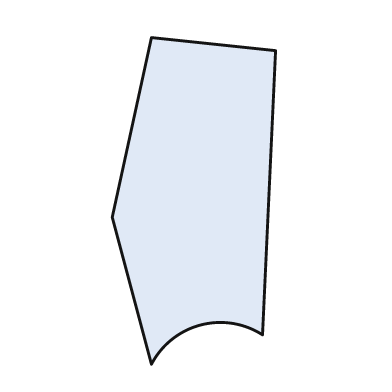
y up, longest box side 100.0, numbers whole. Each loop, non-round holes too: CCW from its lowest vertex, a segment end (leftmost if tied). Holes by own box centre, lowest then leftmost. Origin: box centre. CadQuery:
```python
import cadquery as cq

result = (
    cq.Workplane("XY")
    .moveTo(-13.0, -50.0)
    .threePointArc((2.0, -38.0), (21.0, -41.0))
    .lineTo(25.0, 46.0)
    .lineTo(-13.0, 50.0)
    .lineTo(-25.0, -5.0)
    .close()
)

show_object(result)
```